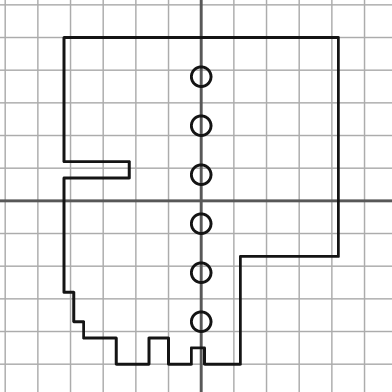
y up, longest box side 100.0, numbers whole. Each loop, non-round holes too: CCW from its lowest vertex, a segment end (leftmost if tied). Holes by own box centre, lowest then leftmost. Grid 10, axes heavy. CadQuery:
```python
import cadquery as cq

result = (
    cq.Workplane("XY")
    .moveTo(-26.0, -50.0)
    .lineTo(-16.0, -50.0)
    .lineTo(-16.0, -42.0)
    .lineTo(-10.0, -42.0)
    .lineTo(-10.0, -50.0)
    .lineTo(-3.0, -50.0)
    .lineTo(-3.0, -45.0)
    .lineTo(1.0, -45.0)
    .lineTo(1.0, -50.0)
    .lineTo(12.0, -50.0)
    .lineTo(12.0, -17.0)
    .lineTo(42.0, -17.0)
    .lineTo(42.0, 50.0)
    .lineTo(-42.0, 50.0)
    .lineTo(-42.0, 12.0)
    .lineTo(-22.0, 12.0)
    .lineTo(-22.0, 7.0)
    .lineTo(-42.0, 7.0)
    .lineTo(-42.0, -28.0)
    .lineTo(-39.0, -28.0)
    .lineTo(-39.0, -37.0)
    .lineTo(-36.0, -37.0)
    .lineTo(-36.0, -42.0)
    .lineTo(-26.0, -42.0)
    .close()
    .moveTo(0.0, -37.0)
    .circle(3.0)
    .moveTo(0.0, -22.0)
    .circle(3.0)
    .moveTo(0.0, -7.0)
    .circle(3.0)
    .moveTo(0.0, 8.0)
    .circle(3.0)
    .moveTo(0.0, 23.0)
    .circle(3.0)
    .moveTo(0.0, 38.0)
    .circle(3.0)
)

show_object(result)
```